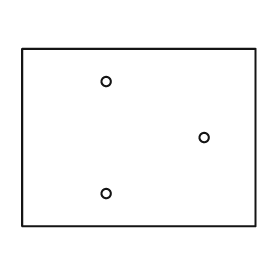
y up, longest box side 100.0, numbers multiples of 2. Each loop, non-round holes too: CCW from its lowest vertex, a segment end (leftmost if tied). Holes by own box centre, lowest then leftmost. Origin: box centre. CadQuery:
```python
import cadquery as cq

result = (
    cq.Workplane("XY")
    .moveTo(-50.0, -38.0)
    .lineTo(50.0, -38.0)
    .lineTo(50.0, 38.0)
    .lineTo(-50.0, 38.0)
    .close()
    .moveTo(-14.0, -24.0)
    .circle(2.0)
    .moveTo(28.0, 0.0)
    .circle(2.0)
    .moveTo(-14.0, 24.0)
    .circle(2.0)
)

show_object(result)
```